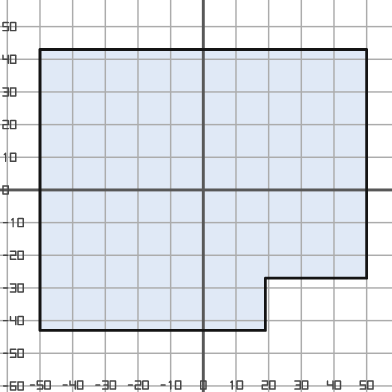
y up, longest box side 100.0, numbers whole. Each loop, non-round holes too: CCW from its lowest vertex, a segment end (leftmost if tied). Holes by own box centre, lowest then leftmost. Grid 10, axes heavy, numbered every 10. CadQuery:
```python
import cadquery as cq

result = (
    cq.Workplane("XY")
    .moveTo(-50.0, -43.0)
    .lineTo(19.0, -43.0)
    .lineTo(19.0, -27.0)
    .lineTo(50.0, -27.0)
    .lineTo(50.0, 43.0)
    .lineTo(-50.0, 43.0)
    .close()
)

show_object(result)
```